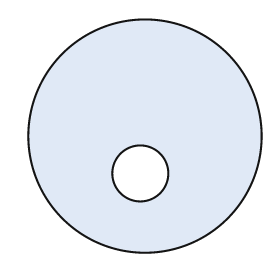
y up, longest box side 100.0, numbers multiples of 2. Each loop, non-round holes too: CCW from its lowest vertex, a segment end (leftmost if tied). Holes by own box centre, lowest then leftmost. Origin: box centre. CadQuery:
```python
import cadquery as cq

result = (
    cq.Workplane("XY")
    .moveTo(0.0, 0.0)
    .circle(50.0)
    .moveTo(-2.0, -16.0)
    .circle(12.0)
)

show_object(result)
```